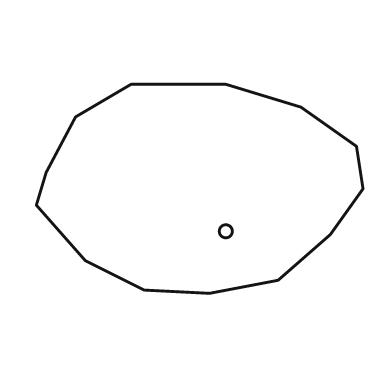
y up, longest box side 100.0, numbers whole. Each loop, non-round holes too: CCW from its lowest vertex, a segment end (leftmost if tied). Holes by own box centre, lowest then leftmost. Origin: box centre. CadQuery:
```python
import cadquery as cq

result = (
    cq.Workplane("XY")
    .moveTo(3.0, -32.0)
    .lineTo(24.0, -28.0)
    .lineTo(40.0, -14.0)
    .lineTo(50.0, 0.0)
    .lineTo(48.0, 13.0)
    .lineTo(31.0, 25.0)
    .lineTo(8.0, 32.0)
    .lineTo(-21.0, 32.0)
    .lineTo(-38.0, 22.0)
    .lineTo(-47.0, 5.0)
    .lineTo(-50.0, -5.0)
    .lineTo(-35.0, -22.0)
    .lineTo(-17.0, -31.0)
    .close()
    .moveTo(8.0, -13.0)
    .circle(2.0)
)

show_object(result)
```